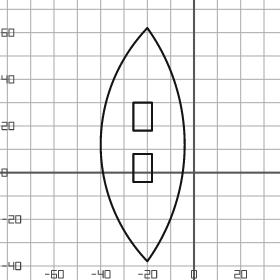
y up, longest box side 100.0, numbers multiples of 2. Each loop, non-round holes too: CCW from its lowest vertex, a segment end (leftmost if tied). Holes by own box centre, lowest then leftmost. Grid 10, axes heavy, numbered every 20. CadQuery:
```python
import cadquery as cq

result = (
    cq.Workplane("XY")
    .moveTo(-20.0, -38.0)
    .threePointArc((-4.0, 12.0), (-20.0, 62.0))
    .threePointArc((-40.0, 12.0), (-20.0, -38.0))
    .close()
    .moveTo(-26.0, -4.0)
    .lineTo(-18.0, -4.0)
    .lineTo(-18.0, 8.0)
    .lineTo(-26.0, 8.0)
    .close()
    .moveTo(-26.0, 18.0)
    .lineTo(-18.0, 18.0)
    .lineTo(-18.0, 30.0)
    .lineTo(-26.0, 30.0)
    .close()
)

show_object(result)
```